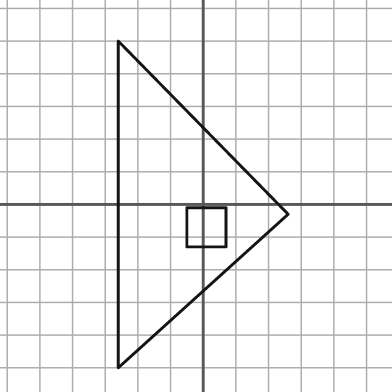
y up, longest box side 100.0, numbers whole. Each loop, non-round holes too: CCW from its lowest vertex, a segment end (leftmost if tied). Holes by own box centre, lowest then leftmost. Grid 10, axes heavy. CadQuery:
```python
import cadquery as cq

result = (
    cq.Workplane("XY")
    .moveTo(-26.0, -50.0)
    .lineTo(26.0, -3.0)
    .lineTo(-26.0, 50.0)
    .close()
    .moveTo(-5.0, -13.0)
    .lineTo(7.0, -13.0)
    .lineTo(7.0, -1.0)
    .lineTo(-5.0, -1.0)
    .close()
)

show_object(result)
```